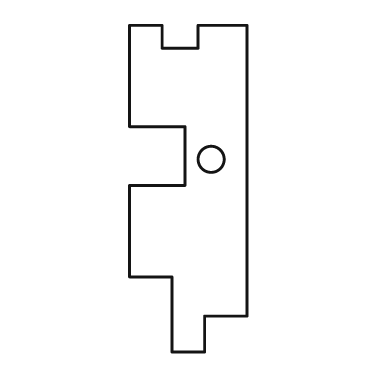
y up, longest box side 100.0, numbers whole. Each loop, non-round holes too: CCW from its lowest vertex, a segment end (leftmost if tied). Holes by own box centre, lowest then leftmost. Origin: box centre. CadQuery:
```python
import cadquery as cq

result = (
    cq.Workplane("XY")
    .moveTo(-5.0, -50.0)
    .lineTo(5.0, -50.0)
    .lineTo(5.0, -39.0)
    .lineTo(18.0, -39.0)
    .lineTo(18.0, 50.0)
    .lineTo(3.0, 50.0)
    .lineTo(3.0, 43.0)
    .lineTo(-8.0, 43.0)
    .lineTo(-8.0, 50.0)
    .lineTo(-18.0, 50.0)
    .lineTo(-18.0, 19.0)
    .lineTo(-1.0, 19.0)
    .lineTo(-1.0, 1.0)
    .lineTo(-18.0, 1.0)
    .lineTo(-18.0, -27.0)
    .lineTo(-5.0, -27.0)
    .close()
    .moveTo(7.0, 9.0)
    .circle(4.0)
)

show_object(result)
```